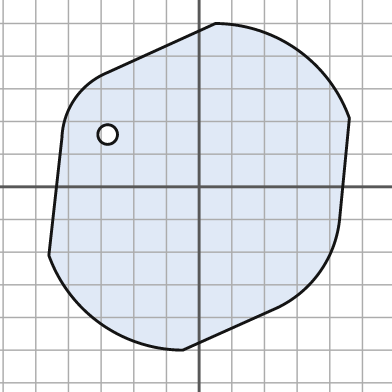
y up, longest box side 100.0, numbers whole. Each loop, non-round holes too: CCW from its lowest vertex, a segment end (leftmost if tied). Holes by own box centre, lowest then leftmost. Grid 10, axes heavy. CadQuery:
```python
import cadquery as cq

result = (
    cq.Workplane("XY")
    .moveTo(-5.0, -50.0)
    .lineTo(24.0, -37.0)
    .threePointArc((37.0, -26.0), (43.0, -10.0))
    .lineTo(46.0, 21.0)
    .threePointArc((30.0, 42.0), (5.0, 50.0))
    .lineTo(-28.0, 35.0)
    .threePointArc((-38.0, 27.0), (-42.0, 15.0))
    .lineTo(-46.0, -21.0)
    .threePointArc((-30.0, -42.0), (-5.0, -50.0))
    .close()
    .moveTo(-28.0, 16.0)
    .circle(3.0)
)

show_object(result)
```